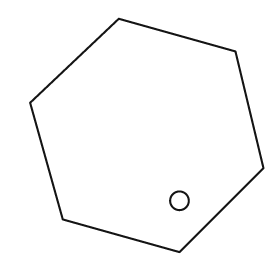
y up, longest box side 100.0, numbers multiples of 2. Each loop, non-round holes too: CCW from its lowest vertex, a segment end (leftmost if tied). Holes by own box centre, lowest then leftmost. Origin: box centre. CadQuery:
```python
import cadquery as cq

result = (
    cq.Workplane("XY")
    .moveTo(14.0, -50.0)
    .lineTo(50.0, -14.0)
    .lineTo(38.0, 36.0)
    .lineTo(-12.0, 50.0)
    .lineTo(-50.0, 14.0)
    .lineTo(-36.0, -36.0)
    .close()
    .moveTo(14.0, -28.0)
    .circle(4.0)
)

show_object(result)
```